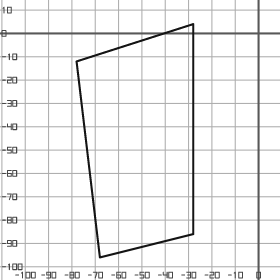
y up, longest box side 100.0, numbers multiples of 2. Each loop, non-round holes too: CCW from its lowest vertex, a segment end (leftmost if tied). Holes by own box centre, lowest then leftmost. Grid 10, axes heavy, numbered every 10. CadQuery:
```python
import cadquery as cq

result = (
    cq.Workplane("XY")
    .moveTo(-68.0, -96.0)
    .lineTo(-28.0, -86.0)
    .lineTo(-28.0, 4.0)
    .lineTo(-78.0, -12.0)
    .close()
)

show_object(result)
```